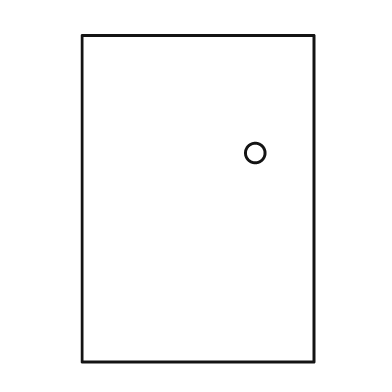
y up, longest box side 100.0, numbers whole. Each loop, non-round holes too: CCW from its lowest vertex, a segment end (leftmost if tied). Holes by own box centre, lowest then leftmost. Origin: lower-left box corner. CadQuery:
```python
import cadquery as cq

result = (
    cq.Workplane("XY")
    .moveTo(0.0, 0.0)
    .lineTo(71.0, 0.0)
    .lineTo(71.0, 100.0)
    .lineTo(0.0, 100.0)
    .close()
    .moveTo(53.0, 64.0)
    .circle(3.0)
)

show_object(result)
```